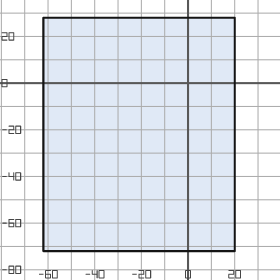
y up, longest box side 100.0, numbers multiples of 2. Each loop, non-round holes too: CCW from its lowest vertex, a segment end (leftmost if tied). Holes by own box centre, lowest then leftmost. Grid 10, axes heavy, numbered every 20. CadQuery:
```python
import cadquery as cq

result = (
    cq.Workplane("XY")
    .moveTo(-62.0, -72.0)
    .lineTo(20.0, -72.0)
    .lineTo(20.0, 28.0)
    .lineTo(-62.0, 28.0)
    .close()
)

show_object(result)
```